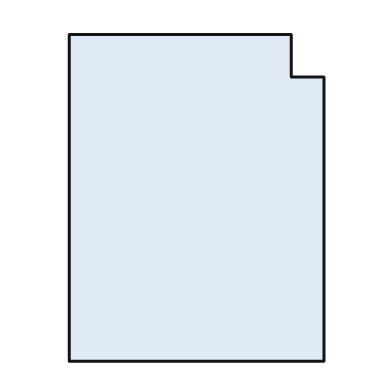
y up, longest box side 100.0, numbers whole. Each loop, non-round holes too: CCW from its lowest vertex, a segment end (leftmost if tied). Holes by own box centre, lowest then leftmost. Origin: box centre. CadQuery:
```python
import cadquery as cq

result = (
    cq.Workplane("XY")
    .moveTo(-39.0, -50.0)
    .lineTo(39.0, -50.0)
    .lineTo(39.0, 37.0)
    .lineTo(29.0, 37.0)
    .lineTo(29.0, 50.0)
    .lineTo(-39.0, 50.0)
    .close()
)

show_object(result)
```